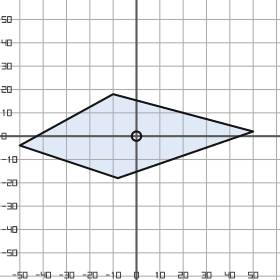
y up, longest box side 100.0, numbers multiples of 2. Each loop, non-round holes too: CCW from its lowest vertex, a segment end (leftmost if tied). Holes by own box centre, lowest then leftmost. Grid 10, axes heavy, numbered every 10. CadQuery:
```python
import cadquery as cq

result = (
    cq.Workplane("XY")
    .moveTo(-8.0, -18.0)
    .lineTo(50.0, 2.0)
    .lineTo(-10.0, 18.0)
    .lineTo(-50.0, -4.0)
    .close()
    .moveTo(0.0, 0.0)
    .circle(2.0)
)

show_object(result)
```